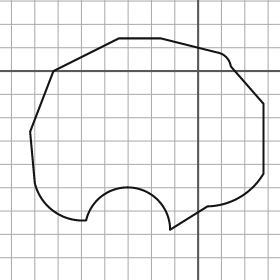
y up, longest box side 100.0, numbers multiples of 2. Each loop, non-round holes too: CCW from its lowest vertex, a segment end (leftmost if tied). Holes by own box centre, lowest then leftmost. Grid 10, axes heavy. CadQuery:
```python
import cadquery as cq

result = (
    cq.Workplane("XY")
    .moveTo(-12.0, -68.0)
    .lineTo(4.0, -58.0)
    .threePointArc((18.0, -54.0), (28.0, -44.0))
    .lineTo(28.0, -14.0)
    .lineTo(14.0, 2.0)
    .threePointArc((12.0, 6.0), (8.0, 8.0))
    .lineTo(-16.0, 14.0)
    .lineTo(-34.0, 14.0)
    .lineTo(-62.0, 0.0)
    .lineTo(-72.0, -26.0)
    .lineTo(-70.0, -48.0)
    .threePointArc((-62.0, -60.0), (-48.0, -64.0))
    .threePointArc((-28.0, -50.0), (-12.0, -68.0))
    .close()
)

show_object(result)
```